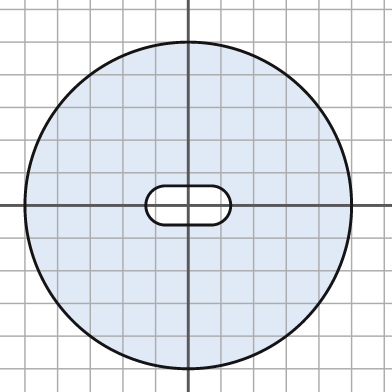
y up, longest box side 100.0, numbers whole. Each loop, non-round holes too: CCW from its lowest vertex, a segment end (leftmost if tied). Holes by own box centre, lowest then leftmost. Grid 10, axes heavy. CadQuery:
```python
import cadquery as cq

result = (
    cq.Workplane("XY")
    .moveTo(0.0, 0.0)
    .circle(50.0)
    .moveTo(-7.0, -6.0)
    .lineTo(7.0, -6.0)
    .threePointArc((13.0, 0.0), (7.0, 6.0))
    .lineTo(-7.0, 6.0)
    .threePointArc((-13.0, 0.0), (-7.0, -6.0))
    .close()
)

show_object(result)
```